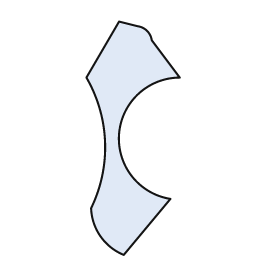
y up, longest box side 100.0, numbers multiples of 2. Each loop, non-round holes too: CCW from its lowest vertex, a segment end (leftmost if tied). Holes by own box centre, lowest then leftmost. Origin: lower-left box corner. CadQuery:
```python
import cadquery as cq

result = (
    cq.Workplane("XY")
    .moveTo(16.0, 0.0)
    .lineTo(36.0, 24.0)
    .threePointArc((14.0, 52.0), (40.0, 76.0))
    .lineTo(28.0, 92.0)
    .threePointArc((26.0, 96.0), (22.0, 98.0))
    .lineTo(14.0, 100.0)
    .lineTo(0.0, 76.0)
    .threePointArc((8.0, 48.0), (2.0, 20.0))
    .threePointArc((6.0, 8.0), (16.0, 0.0))
    .close()
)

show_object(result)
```